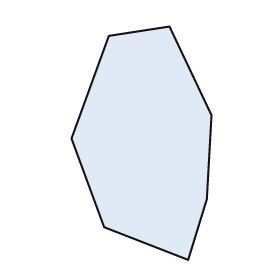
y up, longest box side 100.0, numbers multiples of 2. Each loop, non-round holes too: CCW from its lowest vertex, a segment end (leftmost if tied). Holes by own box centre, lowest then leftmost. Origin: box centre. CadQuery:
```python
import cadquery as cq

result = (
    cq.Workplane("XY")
    .moveTo(20.0, -50.0)
    .lineTo(28.0, -24.0)
    .lineTo(30.0, 12.0)
    .lineTo(12.0, 50.0)
    .lineTo(-14.0, 46.0)
    .lineTo(-30.0, 2.0)
    .lineTo(-16.0, -36.0)
    .close()
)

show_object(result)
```